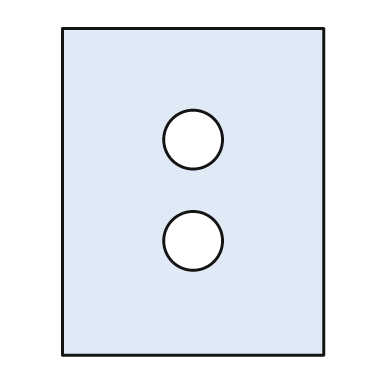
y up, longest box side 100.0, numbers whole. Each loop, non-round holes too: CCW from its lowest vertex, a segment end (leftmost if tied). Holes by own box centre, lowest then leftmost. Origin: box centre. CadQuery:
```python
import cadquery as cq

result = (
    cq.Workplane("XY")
    .moveTo(-40.0, -50.0)
    .lineTo(40.0, -50.0)
    .lineTo(40.0, 50.0)
    .lineTo(-40.0, 50.0)
    .close()
    .moveTo(0.0, -15.0)
    .circle(9.0)
    .moveTo(0.0, 16.0)
    .circle(9.0)
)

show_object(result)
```